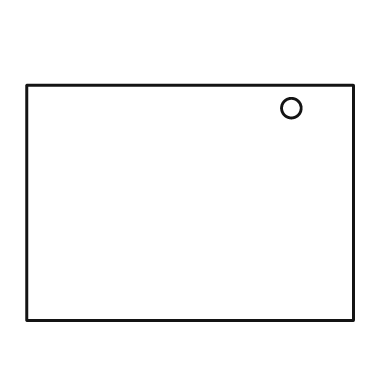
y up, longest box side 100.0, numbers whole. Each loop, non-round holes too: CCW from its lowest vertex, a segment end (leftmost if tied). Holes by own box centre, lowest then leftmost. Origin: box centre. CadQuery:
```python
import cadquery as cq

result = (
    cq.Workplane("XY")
    .moveTo(-50.0, -36.0)
    .lineTo(50.0, -36.0)
    .lineTo(50.0, 36.0)
    .lineTo(-50.0, 36.0)
    .close()
    .moveTo(31.0, 29.0)
    .circle(3.0)
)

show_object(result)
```